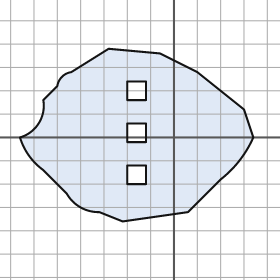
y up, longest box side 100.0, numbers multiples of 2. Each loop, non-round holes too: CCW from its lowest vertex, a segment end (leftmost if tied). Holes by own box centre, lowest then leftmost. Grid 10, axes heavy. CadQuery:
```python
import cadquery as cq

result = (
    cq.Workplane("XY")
    .moveTo(-22.0, -36.0)
    .lineTo(6.0, -32.0)
    .lineTo(20.0, -18.0)
    .threePointArc((28.0, -10.0), (34.0, 0.0))
    .lineTo(30.0, 12.0)
    .lineTo(10.0, 28.0)
    .lineTo(-6.0, 36.0)
    .lineTo(-28.0, 38.0)
    .lineTo(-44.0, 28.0)
    .threePointArc((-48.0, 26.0), (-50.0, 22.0))
    .lineTo(-56.0, 16.0)
    .threePointArc((-58.0, 6.0), (-66.0, 0.0))
    .threePointArc((-62.0, -8.0), (-56.0, -14.0))
    .lineTo(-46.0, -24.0)
    .threePointArc((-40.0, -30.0), (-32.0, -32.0))
    .close()
    .moveTo(-20.0, -20.0)
    .lineTo(-12.0, -20.0)
    .lineTo(-12.0, -12.0)
    .lineTo(-20.0, -12.0)
    .close()
    .moveTo(-20.0, -2.0)
    .lineTo(-12.0, -2.0)
    .lineTo(-12.0, 6.0)
    .lineTo(-20.0, 6.0)
    .close()
    .moveTo(-20.0, 16.0)
    .lineTo(-12.0, 16.0)
    .lineTo(-12.0, 24.0)
    .lineTo(-20.0, 24.0)
    .close()
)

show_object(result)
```